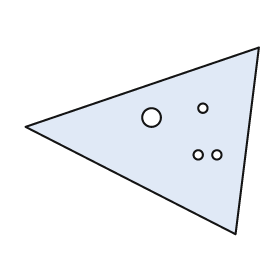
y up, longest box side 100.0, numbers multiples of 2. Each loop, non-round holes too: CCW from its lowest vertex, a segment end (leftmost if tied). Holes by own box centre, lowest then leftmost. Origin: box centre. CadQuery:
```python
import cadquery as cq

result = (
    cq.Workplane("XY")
    .moveTo(40.0, -40.0)
    .lineTo(50.0, 40.0)
    .lineTo(-50.0, 6.0)
    .close()
    .moveTo(24.0, -6.0)
    .circle(2.0)
    .moveTo(32.0, -6.0)
    .circle(2.0)
    .moveTo(4.0, 10.0)
    .circle(4.0)
    .moveTo(26.0, 14.0)
    .circle(2.0)
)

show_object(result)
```